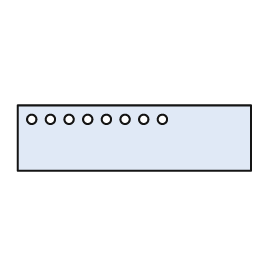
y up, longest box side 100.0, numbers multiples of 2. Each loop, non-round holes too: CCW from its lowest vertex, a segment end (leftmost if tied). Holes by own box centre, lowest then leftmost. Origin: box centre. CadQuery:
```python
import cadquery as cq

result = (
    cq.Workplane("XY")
    .moveTo(-50.0, -14.0)
    .lineTo(50.0, -14.0)
    .lineTo(50.0, 14.0)
    .lineTo(-50.0, 14.0)
    .close()
    .moveTo(-44.0, 8.0)
    .circle(2.0)
    .moveTo(-36.0, 8.0)
    .circle(2.0)
    .moveTo(-28.0, 8.0)
    .circle(2.0)
    .moveTo(-20.0, 8.0)
    .circle(2.0)
    .moveTo(-12.0, 8.0)
    .circle(2.0)
    .moveTo(-4.0, 8.0)
    .circle(2.0)
    .moveTo(4.0, 8.0)
    .circle(2.0)
    .moveTo(12.0, 8.0)
    .circle(2.0)
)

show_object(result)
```